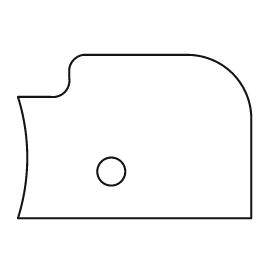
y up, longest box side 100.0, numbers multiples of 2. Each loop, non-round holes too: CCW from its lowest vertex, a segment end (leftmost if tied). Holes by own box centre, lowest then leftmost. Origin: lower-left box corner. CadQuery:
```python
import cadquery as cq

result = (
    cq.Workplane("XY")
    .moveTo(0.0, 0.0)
    .lineTo(100.0, 0.0)
    .lineTo(100.0, 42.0)
    .threePointArc((92.0, 62.0), (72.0, 70.0))
    .lineTo(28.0, 70.0)
    .threePointArc((24.0, 68.0), (22.0, 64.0))
    .lineTo(22.0, 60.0)
    .threePointArc((20.0, 54.0), (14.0, 52.0))
    .lineTo(0.0, 52.0)
    .threePointArc((4.0, 26.0), (0.0, 0.0))
    .close()
    .moveTo(40.0, 20.0)
    .circle(6.0)
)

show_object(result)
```